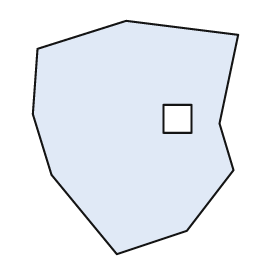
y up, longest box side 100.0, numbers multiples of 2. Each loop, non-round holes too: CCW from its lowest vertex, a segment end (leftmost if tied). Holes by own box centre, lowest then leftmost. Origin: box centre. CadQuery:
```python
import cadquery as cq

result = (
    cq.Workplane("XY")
    .moveTo(-8.0, -50.0)
    .lineTo(22.0, -40.0)
    .lineTo(42.0, -14.0)
    .lineTo(36.0, 6.0)
    .lineTo(44.0, 44.0)
    .lineTo(-4.0, 50.0)
    .lineTo(-42.0, 38.0)
    .lineTo(-44.0, 10.0)
    .lineTo(-36.0, -16.0)
    .close()
    .moveTo(12.0, 2.0)
    .lineTo(24.0, 2.0)
    .lineTo(24.0, 14.0)
    .lineTo(12.0, 14.0)
    .close()
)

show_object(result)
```